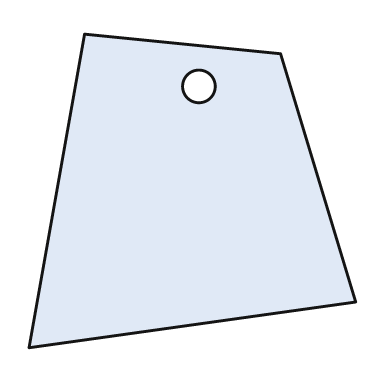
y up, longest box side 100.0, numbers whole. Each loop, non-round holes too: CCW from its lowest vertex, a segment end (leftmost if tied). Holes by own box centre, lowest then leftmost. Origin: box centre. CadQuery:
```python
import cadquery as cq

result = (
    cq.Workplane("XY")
    .moveTo(-50.0, -48.0)
    .lineTo(50.0, -34.0)
    .lineTo(27.0, 42.0)
    .lineTo(-33.0, 48.0)
    .close()
    .moveTo(2.0, 32.0)
    .circle(5.0)
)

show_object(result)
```